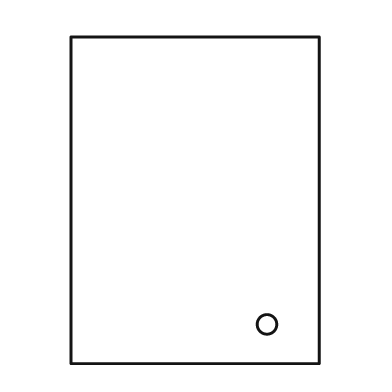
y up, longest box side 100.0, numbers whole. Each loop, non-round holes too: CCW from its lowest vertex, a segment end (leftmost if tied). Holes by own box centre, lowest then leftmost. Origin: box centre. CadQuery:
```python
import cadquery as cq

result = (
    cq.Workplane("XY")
    .moveTo(-38.0, -50.0)
    .lineTo(38.0, -50.0)
    .lineTo(38.0, 50.0)
    .lineTo(-38.0, 50.0)
    .close()
    .moveTo(22.0, -38.0)
    .circle(3.0)
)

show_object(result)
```